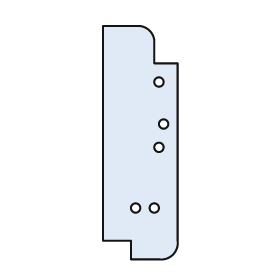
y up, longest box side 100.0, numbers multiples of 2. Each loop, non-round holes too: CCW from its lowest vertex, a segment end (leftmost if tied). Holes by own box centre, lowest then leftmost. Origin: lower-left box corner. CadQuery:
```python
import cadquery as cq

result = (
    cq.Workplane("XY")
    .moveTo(12.0, 0.0)
    .lineTo(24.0, 0.0)
    .threePointArc((30.0, 2.0), (32.0, 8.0))
    .lineTo(32.0, 84.0)
    .lineTo(22.0, 84.0)
    .lineTo(22.0, 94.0)
    .threePointArc((20.0, 98.0), (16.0, 100.0))
    .lineTo(0.0, 100.0)
    .lineTo(0.0, 8.0)
    .lineTo(12.0, 8.0)
    .close()
    .moveTo(14.0, 22.0)
    .circle(2.0)
    .moveTo(22.0, 22.0)
    .circle(2.0)
    .moveTo(24.0, 48.0)
    .circle(2.0)
    .moveTo(26.0, 58.0)
    .circle(2.0)
    .moveTo(24.0, 76.0)
    .circle(2.0)
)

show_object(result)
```